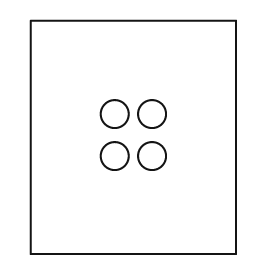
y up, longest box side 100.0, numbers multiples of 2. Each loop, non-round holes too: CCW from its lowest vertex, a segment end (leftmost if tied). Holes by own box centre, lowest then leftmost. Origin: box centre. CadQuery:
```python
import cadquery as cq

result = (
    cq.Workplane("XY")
    .moveTo(-44.0, -50.0)
    .lineTo(44.0, -50.0)
    .lineTo(44.0, 50.0)
    .lineTo(-44.0, 50.0)
    .close()
    .moveTo(-8.0, -8.0)
    .circle(6.0)
    .moveTo(8.0, -8.0)
    .circle(6.0)
    .moveTo(-8.0, 10.0)
    .circle(6.0)
    .moveTo(8.0, 10.0)
    .circle(6.0)
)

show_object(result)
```